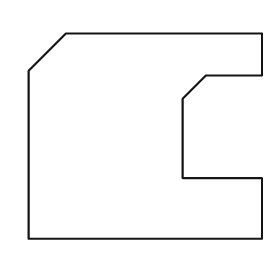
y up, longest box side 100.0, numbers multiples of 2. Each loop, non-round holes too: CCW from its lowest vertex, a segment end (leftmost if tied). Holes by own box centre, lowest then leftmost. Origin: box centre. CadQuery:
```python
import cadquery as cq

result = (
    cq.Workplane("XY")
    .moveTo(-50.0, -44.0)
    .lineTo(50.0, -44.0)
    .lineTo(50.0, -18.0)
    .lineTo(16.0, -18.0)
    .lineTo(16.0, 16.0)
    .lineTo(26.0, 26.0)
    .lineTo(50.0, 26.0)
    .lineTo(50.0, 44.0)
    .lineTo(-34.0, 44.0)
    .lineTo(-50.0, 28.0)
    .close()
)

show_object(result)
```